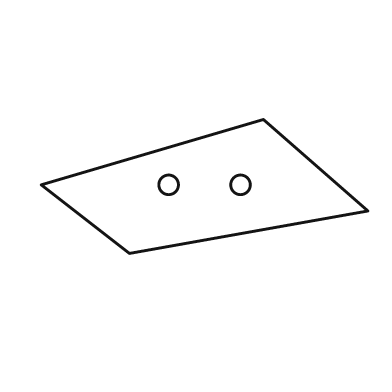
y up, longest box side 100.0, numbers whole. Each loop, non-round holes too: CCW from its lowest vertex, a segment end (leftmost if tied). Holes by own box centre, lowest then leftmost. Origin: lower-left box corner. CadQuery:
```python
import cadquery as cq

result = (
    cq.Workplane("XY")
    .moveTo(27.0, 0.0)
    .lineTo(100.0, 13.0)
    .lineTo(68.0, 41.0)
    .lineTo(0.0, 21.0)
    .close()
    .moveTo(39.0, 21.0)
    .circle(3.0)
    .moveTo(61.0, 21.0)
    .circle(3.0)
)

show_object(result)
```